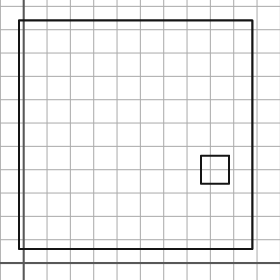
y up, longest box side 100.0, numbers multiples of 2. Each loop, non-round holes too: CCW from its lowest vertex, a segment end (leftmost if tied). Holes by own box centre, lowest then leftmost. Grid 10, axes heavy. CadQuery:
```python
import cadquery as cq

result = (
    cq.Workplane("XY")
    .moveTo(-2.0, 6.0)
    .lineTo(98.0, 6.0)
    .lineTo(98.0, 104.0)
    .lineTo(-2.0, 104.0)
    .close()
    .moveTo(76.0, 34.0)
    .lineTo(88.0, 34.0)
    .lineTo(88.0, 46.0)
    .lineTo(76.0, 46.0)
    .close()
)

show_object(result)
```